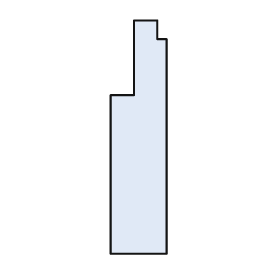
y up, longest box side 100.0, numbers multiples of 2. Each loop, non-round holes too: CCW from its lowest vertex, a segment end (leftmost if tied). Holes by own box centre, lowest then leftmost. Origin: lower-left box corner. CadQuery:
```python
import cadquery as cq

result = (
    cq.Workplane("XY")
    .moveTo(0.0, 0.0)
    .lineTo(24.0, 0.0)
    .lineTo(24.0, 92.0)
    .lineTo(20.0, 92.0)
    .lineTo(20.0, 100.0)
    .lineTo(10.0, 100.0)
    .lineTo(10.0, 68.0)
    .lineTo(0.0, 68.0)
    .close()
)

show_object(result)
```